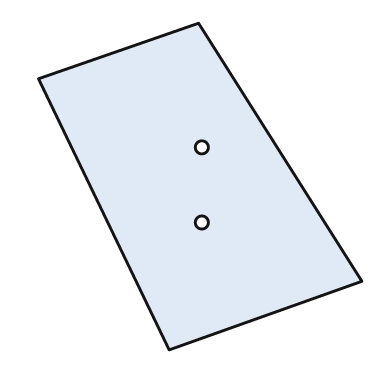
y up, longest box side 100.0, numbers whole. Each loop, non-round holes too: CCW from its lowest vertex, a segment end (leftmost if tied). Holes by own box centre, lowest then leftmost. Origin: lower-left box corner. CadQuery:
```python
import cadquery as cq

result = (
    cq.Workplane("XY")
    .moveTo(40.0, 0.0)
    .lineTo(99.0, 21.0)
    .lineTo(49.0, 100.0)
    .lineTo(0.0, 83.0)
    .close()
    .moveTo(50.0, 39.0)
    .circle(2.0)
    .moveTo(50.0, 62.0)
    .circle(2.0)
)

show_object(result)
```